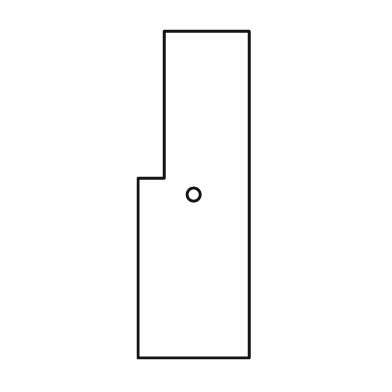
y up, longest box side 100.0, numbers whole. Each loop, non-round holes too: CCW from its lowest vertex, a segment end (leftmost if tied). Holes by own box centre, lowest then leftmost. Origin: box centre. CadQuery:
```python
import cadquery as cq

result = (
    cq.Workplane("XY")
    .moveTo(-17.0, -50.0)
    .lineTo(17.0, -50.0)
    .lineTo(17.0, 50.0)
    .lineTo(-9.0, 50.0)
    .lineTo(-9.0, 5.0)
    .lineTo(-17.0, 5.0)
    .close()
    .moveTo(0.0, 0.0)
    .circle(2.0)
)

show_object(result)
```